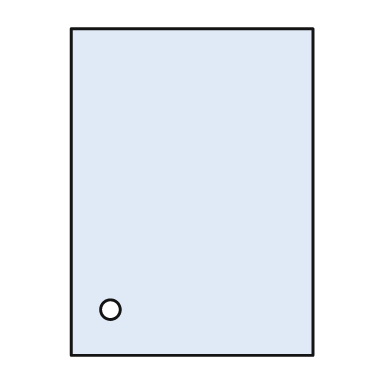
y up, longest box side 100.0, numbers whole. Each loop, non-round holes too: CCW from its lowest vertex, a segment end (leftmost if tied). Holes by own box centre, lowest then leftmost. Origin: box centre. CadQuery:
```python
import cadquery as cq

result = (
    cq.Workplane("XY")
    .moveTo(-37.0, -50.0)
    .lineTo(37.0, -50.0)
    .lineTo(37.0, 50.0)
    .lineTo(-37.0, 50.0)
    .close()
    .moveTo(-25.0, -36.0)
    .circle(3.0)
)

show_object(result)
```